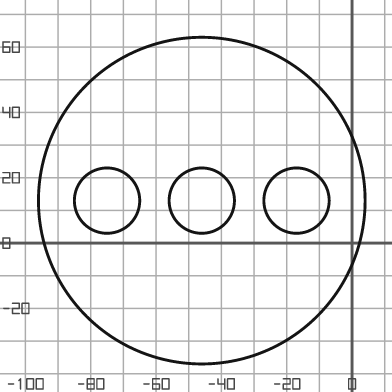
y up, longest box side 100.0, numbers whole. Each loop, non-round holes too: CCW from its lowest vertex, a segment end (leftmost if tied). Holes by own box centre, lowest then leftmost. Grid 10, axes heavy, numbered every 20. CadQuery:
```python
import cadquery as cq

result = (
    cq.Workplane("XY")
    .moveTo(-46.0, 13.0)
    .circle(50.0)
    .moveTo(-75.0, 13.0)
    .circle(10.0)
    .moveTo(-46.0, 13.0)
    .circle(10.0)
    .moveTo(-17.0, 13.0)
    .circle(10.0)
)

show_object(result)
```